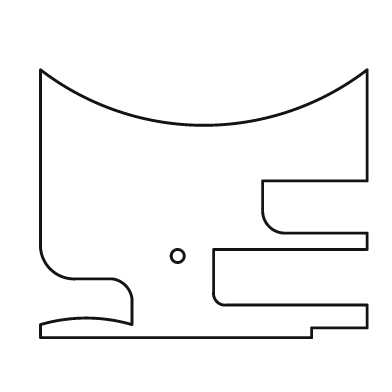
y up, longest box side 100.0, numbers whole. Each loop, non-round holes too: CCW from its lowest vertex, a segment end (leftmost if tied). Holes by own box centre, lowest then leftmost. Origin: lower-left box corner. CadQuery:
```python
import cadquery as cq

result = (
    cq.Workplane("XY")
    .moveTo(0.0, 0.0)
    .lineTo(83.0, 0.0)
    .lineTo(83.0, 3.0)
    .lineTo(100.0, 3.0)
    .lineTo(100.0, 10.0)
    .lineTo(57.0, 10.0)
    .threePointArc((54.0, 11.0), (53.0, 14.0))
    .lineTo(53.0, 27.0)
    .lineTo(100.0, 27.0)
    .lineTo(100.0, 32.0)
    .lineTo(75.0, 32.0)
    .threePointArc((70.0, 34.0), (68.0, 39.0))
    .lineTo(68.0, 48.0)
    .lineTo(100.0, 48.0)
    .lineTo(100.0, 82.0)
    .threePointArc((50.0, 65.0), (0.0, 82.0))
    .lineTo(0.0, 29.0)
    .threePointArc((3.0, 21.0), (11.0, 18.0))
    .lineTo(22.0, 18.0)
    .threePointArc((26.0, 16.0), (28.0, 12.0))
    .lineTo(28.0, 4.0)
    .threePointArc((14.0, 6.0), (0.0, 4.0))
    .close()
    .moveTo(42.0, 25.0)
    .circle(2.0)
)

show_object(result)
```